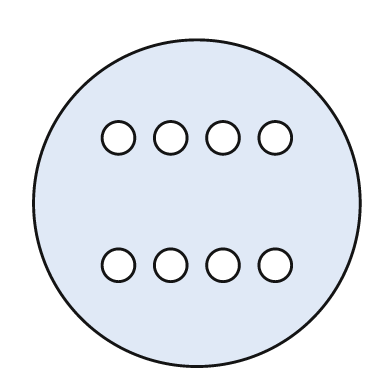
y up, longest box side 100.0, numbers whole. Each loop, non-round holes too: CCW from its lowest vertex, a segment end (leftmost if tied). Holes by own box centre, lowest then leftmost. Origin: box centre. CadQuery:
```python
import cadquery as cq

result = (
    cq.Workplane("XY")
    .moveTo(0.0, 0.0)
    .circle(50.0)
    .moveTo(-24.0, -19.0)
    .circle(5.0)
    .moveTo(-8.0, -19.0)
    .circle(5.0)
    .moveTo(8.0, -19.0)
    .circle(5.0)
    .moveTo(24.0, -19.0)
    .circle(5.0)
    .moveTo(-24.0, 20.0)
    .circle(5.0)
    .moveTo(-8.0, 20.0)
    .circle(5.0)
    .moveTo(8.0, 20.0)
    .circle(5.0)
    .moveTo(24.0, 20.0)
    .circle(5.0)
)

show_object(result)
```